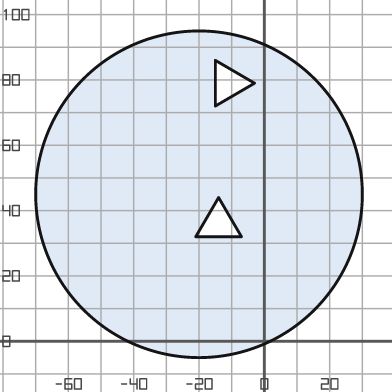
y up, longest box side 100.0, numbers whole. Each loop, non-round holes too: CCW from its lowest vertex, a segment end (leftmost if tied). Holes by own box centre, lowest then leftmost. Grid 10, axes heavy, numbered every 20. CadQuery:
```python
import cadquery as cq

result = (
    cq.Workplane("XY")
    .moveTo(-20.0, 45.0)
    .circle(50.0)
    .moveTo(-21.0, 32.0)
    .lineTo(-7.0, 32.0)
    .lineTo(-14.0, 44.0)
    .close()
    .moveTo(-15.0, 72.0)
    .lineTo(-3.0, 79.0)
    .lineTo(-15.0, 86.0)
    .close()
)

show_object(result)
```